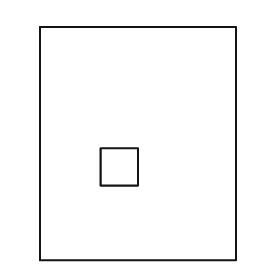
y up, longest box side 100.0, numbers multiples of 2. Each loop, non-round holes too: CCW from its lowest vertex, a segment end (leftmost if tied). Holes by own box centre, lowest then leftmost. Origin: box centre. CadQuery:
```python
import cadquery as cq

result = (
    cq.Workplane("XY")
    .moveTo(-42.0, -50.0)
    .lineTo(42.0, -50.0)
    .lineTo(42.0, 50.0)
    .lineTo(-42.0, 50.0)
    .close()
    .moveTo(-16.0, -18.0)
    .lineTo(0.0, -18.0)
    .lineTo(0.0, -2.0)
    .lineTo(-16.0, -2.0)
    .close()
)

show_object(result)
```